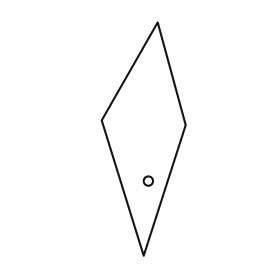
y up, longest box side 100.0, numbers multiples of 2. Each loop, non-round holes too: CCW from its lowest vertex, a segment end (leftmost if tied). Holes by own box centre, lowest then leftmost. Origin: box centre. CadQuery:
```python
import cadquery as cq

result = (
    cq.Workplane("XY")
    .moveTo(0.0, -50.0)
    .lineTo(18.0, 6.0)
    .lineTo(6.0, 50.0)
    .lineTo(-18.0, 8.0)
    .close()
    .moveTo(2.0, -18.0)
    .circle(2.0)
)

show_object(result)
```